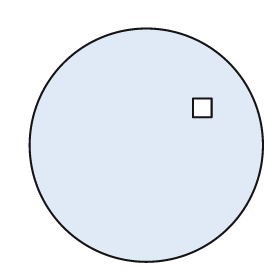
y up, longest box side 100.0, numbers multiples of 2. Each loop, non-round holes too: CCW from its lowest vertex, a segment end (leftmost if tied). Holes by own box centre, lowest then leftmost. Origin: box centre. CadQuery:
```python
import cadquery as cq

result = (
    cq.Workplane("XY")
    .moveTo(0.0, 0.0)
    .circle(50.0)
    .moveTo(20.0, 12.0)
    .lineTo(28.0, 12.0)
    .lineTo(28.0, 20.0)
    .lineTo(20.0, 20.0)
    .close()
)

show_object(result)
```